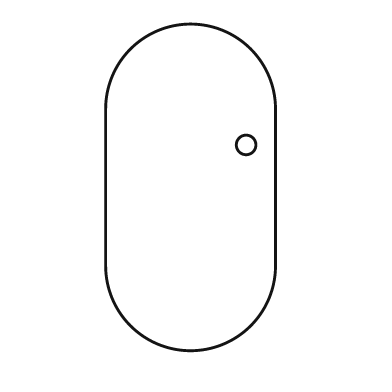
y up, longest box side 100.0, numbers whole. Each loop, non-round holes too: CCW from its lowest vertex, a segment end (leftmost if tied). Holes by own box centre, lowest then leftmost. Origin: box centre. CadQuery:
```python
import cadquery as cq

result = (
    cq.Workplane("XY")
    .moveTo(-26.0, -24.0)
    .threePointArc((0.0, -50.0), (26.0, -24.0))
    .lineTo(26.0, 24.0)
    .threePointArc((0.0, 50.0), (-26.0, 24.0))
    .close()
    .moveTo(17.0, 13.0)
    .circle(3.0)
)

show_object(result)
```